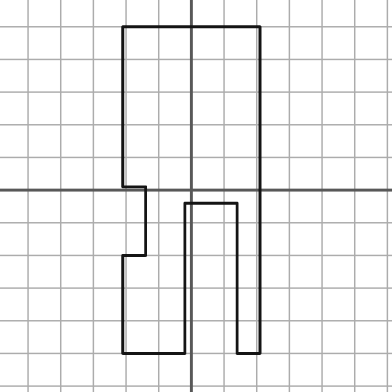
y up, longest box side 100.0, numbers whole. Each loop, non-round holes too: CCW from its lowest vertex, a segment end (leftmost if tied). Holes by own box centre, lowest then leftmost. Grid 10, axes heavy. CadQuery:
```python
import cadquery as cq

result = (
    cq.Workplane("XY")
    .moveTo(-21.0, -50.0)
    .lineTo(-2.0, -50.0)
    .lineTo(-2.0, -4.0)
    .lineTo(14.0, -4.0)
    .lineTo(14.0, -50.0)
    .lineTo(21.0, -50.0)
    .lineTo(21.0, 50.0)
    .lineTo(-21.0, 50.0)
    .lineTo(-21.0, 1.0)
    .lineTo(-14.0, 1.0)
    .lineTo(-14.0, -20.0)
    .lineTo(-21.0, -20.0)
    .close()
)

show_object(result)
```